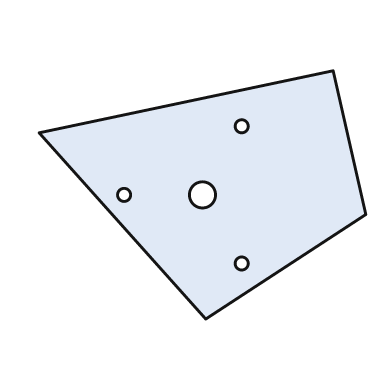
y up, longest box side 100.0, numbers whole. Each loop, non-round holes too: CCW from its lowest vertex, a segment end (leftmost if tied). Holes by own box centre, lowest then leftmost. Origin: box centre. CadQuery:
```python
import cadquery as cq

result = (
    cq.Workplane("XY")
    .moveTo(1.0, -38.0)
    .lineTo(50.0, -6.0)
    .lineTo(40.0, 38.0)
    .lineTo(-50.0, 19.0)
    .close()
    .moveTo(12.0, -21.0)
    .circle(2.0)
    .moveTo(-24.0, 0.0)
    .circle(2.0)
    .moveTo(0.0, 0.0)
    .circle(4.0)
    .moveTo(12.0, 21.0)
    .circle(2.0)
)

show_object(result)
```